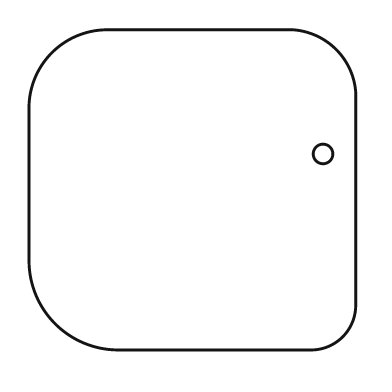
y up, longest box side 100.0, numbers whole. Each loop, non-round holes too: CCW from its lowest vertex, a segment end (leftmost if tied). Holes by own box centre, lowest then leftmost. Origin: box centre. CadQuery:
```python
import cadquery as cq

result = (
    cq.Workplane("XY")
    .moveTo(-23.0, -49.0)
    .lineTo(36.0, -49.0)
    .threePointArc((46.0, -45.0), (50.0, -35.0))
    .lineTo(50.0, 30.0)
    .threePointArc((44.0, 43.0), (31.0, 49.0))
    .lineTo(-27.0, 49.0)
    .threePointArc((-43.0, 42.0), (-50.0, 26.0))
    .lineTo(-50.0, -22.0)
    .threePointArc((-42.0, -41.0), (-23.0, -49.0))
    .close()
    .moveTo(40.0, 11.0)
    .circle(3.0)
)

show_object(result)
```